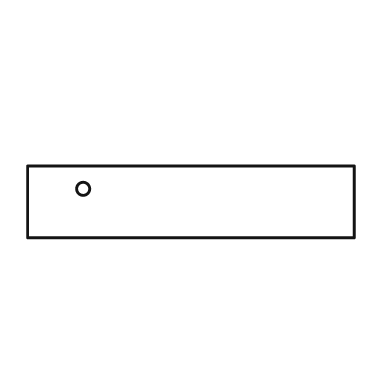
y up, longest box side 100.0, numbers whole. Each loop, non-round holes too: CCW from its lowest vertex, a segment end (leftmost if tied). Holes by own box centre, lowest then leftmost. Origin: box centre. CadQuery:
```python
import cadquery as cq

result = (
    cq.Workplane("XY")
    .moveTo(-50.0, -11.0)
    .lineTo(50.0, -11.0)
    .lineTo(50.0, 11.0)
    .lineTo(-50.0, 11.0)
    .close()
    .moveTo(-33.0, 4.0)
    .circle(2.0)
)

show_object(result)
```